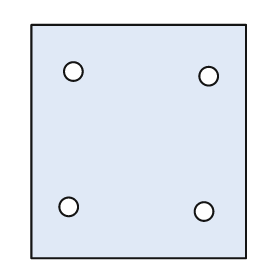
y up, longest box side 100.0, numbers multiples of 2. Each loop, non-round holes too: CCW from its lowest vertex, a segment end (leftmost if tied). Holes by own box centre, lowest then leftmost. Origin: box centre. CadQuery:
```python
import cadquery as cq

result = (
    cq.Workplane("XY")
    .moveTo(-46.0, -50.0)
    .lineTo(46.0, -50.0)
    .lineTo(46.0, 50.0)
    .lineTo(-46.0, 50.0)
    .close()
    .moveTo(28.0, -30.0)
    .circle(4.0)
    .moveTo(-30.0, -28.0)
    .circle(4.0)
    .moveTo(30.0, 28.0)
    .circle(4.0)
    .moveTo(-28.0, 30.0)
    .circle(4.0)
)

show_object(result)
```